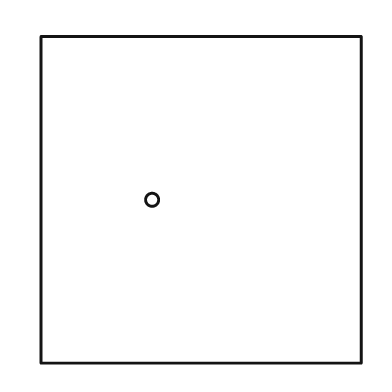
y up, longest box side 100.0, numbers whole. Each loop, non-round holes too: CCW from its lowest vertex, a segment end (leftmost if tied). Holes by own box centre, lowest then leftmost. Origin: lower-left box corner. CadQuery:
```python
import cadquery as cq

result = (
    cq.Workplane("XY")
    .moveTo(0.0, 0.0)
    .lineTo(98.0, 0.0)
    .lineTo(98.0, 100.0)
    .lineTo(0.0, 100.0)
    .close()
    .moveTo(34.0, 50.0)
    .circle(2.0)
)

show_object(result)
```